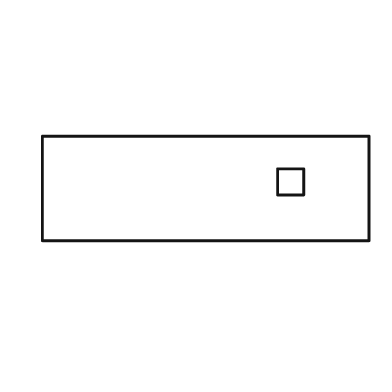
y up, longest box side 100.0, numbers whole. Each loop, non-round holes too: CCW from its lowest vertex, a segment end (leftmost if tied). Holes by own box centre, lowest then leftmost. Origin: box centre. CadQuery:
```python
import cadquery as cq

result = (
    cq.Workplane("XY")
    .moveTo(-50.0, -16.0)
    .lineTo(50.0, -16.0)
    .lineTo(50.0, 16.0)
    .lineTo(-50.0, 16.0)
    .close()
    .moveTo(22.0, -2.0)
    .lineTo(30.0, -2.0)
    .lineTo(30.0, 6.0)
    .lineTo(22.0, 6.0)
    .close()
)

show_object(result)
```